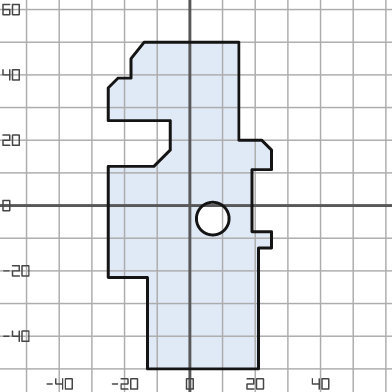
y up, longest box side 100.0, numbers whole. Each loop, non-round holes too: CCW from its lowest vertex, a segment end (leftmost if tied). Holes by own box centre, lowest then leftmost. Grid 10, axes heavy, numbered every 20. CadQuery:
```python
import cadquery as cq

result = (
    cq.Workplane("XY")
    .moveTo(-13.0, -50.0)
    .lineTo(21.0, -50.0)
    .lineTo(21.0, -13.0)
    .lineTo(25.0, -13.0)
    .lineTo(25.0, -8.0)
    .lineTo(19.0, -8.0)
    .lineTo(19.0, 11.0)
    .lineTo(25.0, 11.0)
    .lineTo(25.0, 17.0)
    .lineTo(22.0, 20.0)
    .lineTo(15.0, 20.0)
    .lineTo(15.0, 50.0)
    .lineTo(-14.0, 50.0)
    .lineTo(-18.0, 45.0)
    .lineTo(-18.0, 39.0)
    .lineTo(-22.0, 39.0)
    .lineTo(-25.0, 36.0)
    .lineTo(-25.0, 26.0)
    .lineTo(-6.0, 26.0)
    .lineTo(-6.0, 17.0)
    .lineTo(-11.0, 12.0)
    .lineTo(-25.0, 12.0)
    .lineTo(-25.0, -22.0)
    .lineTo(-13.0, -22.0)
    .close()
    .moveTo(7.0, -4.0)
    .circle(5.0)
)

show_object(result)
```